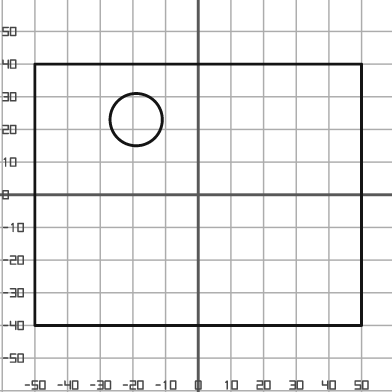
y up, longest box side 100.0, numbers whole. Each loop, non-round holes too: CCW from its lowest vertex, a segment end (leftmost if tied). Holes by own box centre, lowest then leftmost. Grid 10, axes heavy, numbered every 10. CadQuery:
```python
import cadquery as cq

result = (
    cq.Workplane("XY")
    .moveTo(-50.0, -40.0)
    .lineTo(50.0, -40.0)
    .lineTo(50.0, 40.0)
    .lineTo(-50.0, 40.0)
    .close()
    .moveTo(-19.0, 23.0)
    .circle(8.0)
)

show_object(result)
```